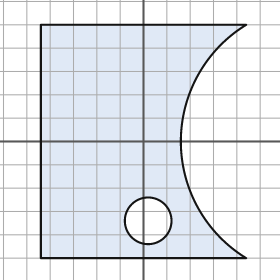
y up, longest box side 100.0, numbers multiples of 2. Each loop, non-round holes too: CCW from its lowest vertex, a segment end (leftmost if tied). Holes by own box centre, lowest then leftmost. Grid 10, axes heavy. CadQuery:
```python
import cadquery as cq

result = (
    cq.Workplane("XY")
    .moveTo(-44.0, -50.0)
    .lineTo(44.0, -50.0)
    .threePointArc((16.0, 0.0), (44.0, 50.0))
    .lineTo(-44.0, 50.0)
    .close()
    .moveTo(2.0, -34.0)
    .circle(10.0)
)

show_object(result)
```